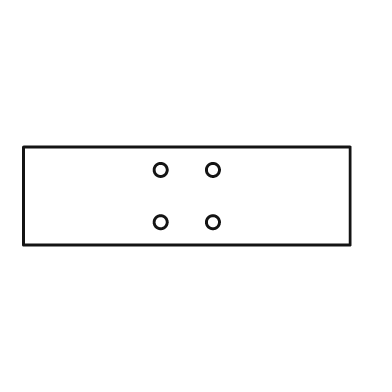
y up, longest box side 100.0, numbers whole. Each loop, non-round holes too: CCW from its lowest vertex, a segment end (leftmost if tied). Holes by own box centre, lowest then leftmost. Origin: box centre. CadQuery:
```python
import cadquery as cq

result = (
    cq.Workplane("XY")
    .moveTo(-50.0, -15.0)
    .lineTo(50.0, -15.0)
    .lineTo(50.0, 15.0)
    .lineTo(-50.0, 15.0)
    .close()
    .moveTo(-8.0, -8.0)
    .circle(2.0)
    .moveTo(8.0, -8.0)
    .circle(2.0)
    .moveTo(-8.0, 8.0)
    .circle(2.0)
    .moveTo(8.0, 8.0)
    .circle(2.0)
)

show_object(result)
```